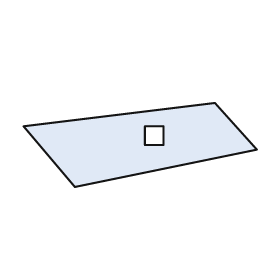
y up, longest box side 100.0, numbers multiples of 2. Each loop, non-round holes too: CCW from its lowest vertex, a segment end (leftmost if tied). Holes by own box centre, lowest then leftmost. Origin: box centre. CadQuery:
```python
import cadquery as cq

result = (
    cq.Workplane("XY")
    .moveTo(-28.0, -18.0)
    .lineTo(50.0, -2.0)
    .lineTo(32.0, 18.0)
    .lineTo(-50.0, 8.0)
    .close()
    .moveTo(2.0, 0.0)
    .lineTo(10.0, 0.0)
    .lineTo(10.0, 8.0)
    .lineTo(2.0, 8.0)
    .close()
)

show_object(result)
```